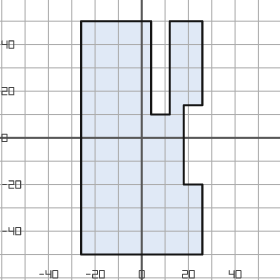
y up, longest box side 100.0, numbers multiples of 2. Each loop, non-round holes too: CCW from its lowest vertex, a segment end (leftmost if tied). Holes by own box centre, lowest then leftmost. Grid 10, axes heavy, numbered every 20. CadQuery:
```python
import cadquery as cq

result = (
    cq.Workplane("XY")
    .moveTo(-26.0, -50.0)
    .lineTo(26.0, -50.0)
    .lineTo(26.0, -20.0)
    .lineTo(18.0, -20.0)
    .lineTo(18.0, 14.0)
    .lineTo(26.0, 14.0)
    .lineTo(26.0, 50.0)
    .lineTo(12.0, 50.0)
    .lineTo(12.0, 10.0)
    .lineTo(4.0, 10.0)
    .lineTo(4.0, 50.0)
    .lineTo(-26.0, 50.0)
    .close()
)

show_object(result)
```